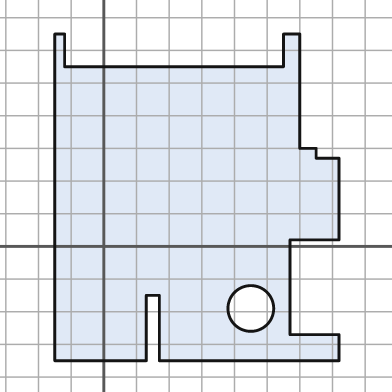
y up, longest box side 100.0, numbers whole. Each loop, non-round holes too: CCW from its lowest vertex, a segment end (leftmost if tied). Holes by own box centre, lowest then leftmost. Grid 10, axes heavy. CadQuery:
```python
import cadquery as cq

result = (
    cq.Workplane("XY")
    .moveTo(-15.0, -35.0)
    .lineTo(13.0, -35.0)
    .lineTo(13.0, -15.0)
    .lineTo(17.0, -15.0)
    .lineTo(17.0, -35.0)
    .lineTo(72.0, -35.0)
    .lineTo(72.0, -27.0)
    .lineTo(57.0, -27.0)
    .lineTo(57.0, 2.0)
    .lineTo(72.0, 2.0)
    .lineTo(72.0, 27.0)
    .lineTo(65.0, 27.0)
    .lineTo(65.0, 30.0)
    .lineTo(60.0, 30.0)
    .lineTo(60.0, 65.0)
    .lineTo(55.0, 65.0)
    .lineTo(55.0, 55.0)
    .lineTo(-12.0, 55.0)
    .lineTo(-12.0, 65.0)
    .lineTo(-15.0, 65.0)
    .close()
    .moveTo(45.0, -19.0)
    .circle(7.0)
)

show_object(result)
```